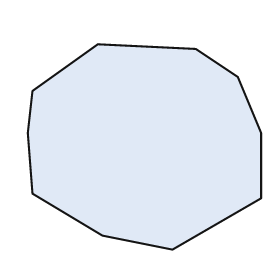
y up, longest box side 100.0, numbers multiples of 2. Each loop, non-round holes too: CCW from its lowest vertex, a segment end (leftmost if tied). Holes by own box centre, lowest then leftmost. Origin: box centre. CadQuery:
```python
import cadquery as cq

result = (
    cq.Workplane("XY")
    .moveTo(12.0, -44.0)
    .lineTo(50.0, -22.0)
    .lineTo(50.0, 6.0)
    .lineTo(40.0, 30.0)
    .lineTo(22.0, 42.0)
    .lineTo(-20.0, 44.0)
    .lineTo(-48.0, 24.0)
    .lineTo(-50.0, 6.0)
    .lineTo(-48.0, -20.0)
    .lineTo(-18.0, -38.0)
    .close()
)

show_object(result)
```